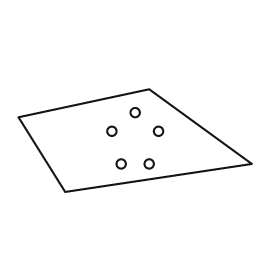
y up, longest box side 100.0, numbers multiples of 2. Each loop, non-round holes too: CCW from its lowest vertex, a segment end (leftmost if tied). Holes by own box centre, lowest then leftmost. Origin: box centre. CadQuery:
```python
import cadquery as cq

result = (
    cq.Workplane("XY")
    .moveTo(-30.0, -22.0)
    .lineTo(50.0, -10.0)
    .lineTo(6.0, 22.0)
    .lineTo(-50.0, 10.0)
    .close()
    .moveTo(-6.0, -10.0)
    .circle(2.0)
    .moveTo(6.0, -10.0)
    .circle(2.0)
    .moveTo(-10.0, 4.0)
    .circle(2.0)
    .moveTo(10.0, 4.0)
    .circle(2.0)
    .moveTo(0.0, 12.0)
    .circle(2.0)
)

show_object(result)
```